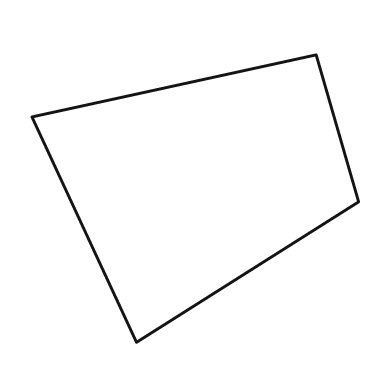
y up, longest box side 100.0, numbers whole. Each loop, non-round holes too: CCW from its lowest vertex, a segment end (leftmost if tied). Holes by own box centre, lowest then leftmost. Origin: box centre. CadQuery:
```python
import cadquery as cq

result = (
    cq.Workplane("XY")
    .moveTo(-18.0, -44.0)
    .lineTo(50.0, -1.0)
    .lineTo(37.0, 44.0)
    .lineTo(-50.0, 25.0)
    .close()
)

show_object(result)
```